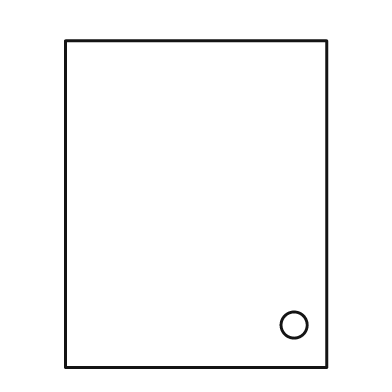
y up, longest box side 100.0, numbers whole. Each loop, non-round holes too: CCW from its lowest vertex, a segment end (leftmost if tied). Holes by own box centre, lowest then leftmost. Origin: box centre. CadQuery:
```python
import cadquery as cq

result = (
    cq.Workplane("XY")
    .moveTo(-40.0, -50.0)
    .lineTo(40.0, -50.0)
    .lineTo(40.0, 50.0)
    .lineTo(-40.0, 50.0)
    .close()
    .moveTo(30.0, -37.0)
    .circle(4.0)
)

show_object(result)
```